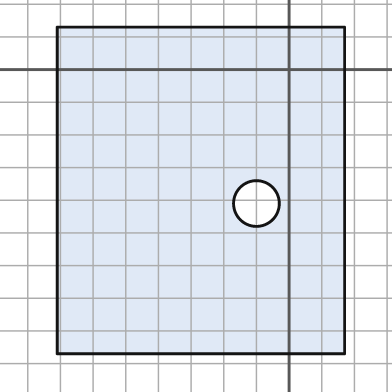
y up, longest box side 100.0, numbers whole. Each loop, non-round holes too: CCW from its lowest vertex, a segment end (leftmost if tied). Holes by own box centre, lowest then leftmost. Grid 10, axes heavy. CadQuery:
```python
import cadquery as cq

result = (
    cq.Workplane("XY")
    .moveTo(-71.0, -87.0)
    .lineTo(17.0, -87.0)
    .lineTo(17.0, 13.0)
    .lineTo(-71.0, 13.0)
    .close()
    .moveTo(-10.0, -41.0)
    .circle(7.0)
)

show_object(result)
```